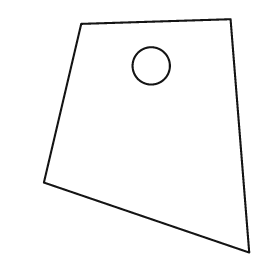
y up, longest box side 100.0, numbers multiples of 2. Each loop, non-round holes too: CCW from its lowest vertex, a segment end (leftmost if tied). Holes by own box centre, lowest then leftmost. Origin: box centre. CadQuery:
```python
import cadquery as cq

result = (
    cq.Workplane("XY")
    .moveTo(44.0, -50.0)
    .lineTo(36.0, 50.0)
    .lineTo(-28.0, 48.0)
    .lineTo(-44.0, -20.0)
    .close()
    .moveTo(2.0, 30.0)
    .circle(8.0)
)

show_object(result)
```